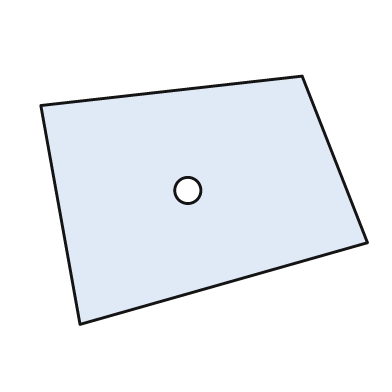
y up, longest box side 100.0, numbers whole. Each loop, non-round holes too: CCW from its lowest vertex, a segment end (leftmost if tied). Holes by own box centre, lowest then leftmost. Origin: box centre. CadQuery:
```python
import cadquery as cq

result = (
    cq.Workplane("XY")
    .moveTo(-38.0, -38.0)
    .lineTo(50.0, -13.0)
    .lineTo(30.0, 38.0)
    .lineTo(-50.0, 29.0)
    .close()
    .moveTo(-5.0, 3.0)
    .circle(4.0)
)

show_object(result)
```